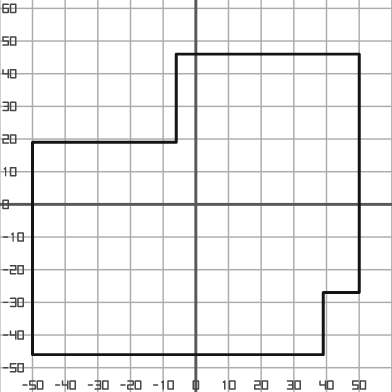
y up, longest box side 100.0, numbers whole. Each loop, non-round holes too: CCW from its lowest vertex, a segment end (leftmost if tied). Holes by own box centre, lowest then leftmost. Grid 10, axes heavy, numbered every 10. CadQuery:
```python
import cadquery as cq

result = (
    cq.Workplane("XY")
    .moveTo(-50.0, -46.0)
    .lineTo(39.0, -46.0)
    .lineTo(39.0, -27.0)
    .lineTo(50.0, -27.0)
    .lineTo(50.0, 46.0)
    .lineTo(-6.0, 46.0)
    .lineTo(-6.0, 19.0)
    .lineTo(-50.0, 19.0)
    .close()
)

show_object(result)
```